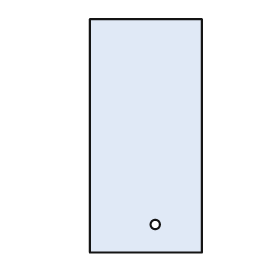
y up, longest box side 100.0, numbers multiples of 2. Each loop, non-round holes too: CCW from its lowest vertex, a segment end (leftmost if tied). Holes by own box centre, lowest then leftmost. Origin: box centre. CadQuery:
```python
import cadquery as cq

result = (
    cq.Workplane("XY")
    .moveTo(-24.0, -50.0)
    .lineTo(24.0, -50.0)
    .lineTo(24.0, 50.0)
    .lineTo(-24.0, 50.0)
    .close()
    .moveTo(4.0, -38.0)
    .circle(2.0)
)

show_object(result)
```